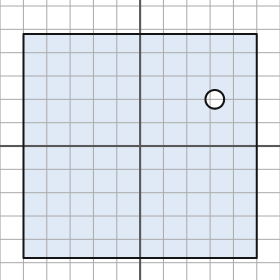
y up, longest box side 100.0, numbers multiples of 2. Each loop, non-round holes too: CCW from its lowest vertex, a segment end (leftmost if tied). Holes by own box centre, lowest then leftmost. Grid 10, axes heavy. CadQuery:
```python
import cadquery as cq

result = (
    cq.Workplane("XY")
    .moveTo(-50.0, -48.0)
    .lineTo(50.0, -48.0)
    .lineTo(50.0, 48.0)
    .lineTo(-50.0, 48.0)
    .close()
    .moveTo(32.0, 20.0)
    .circle(4.0)
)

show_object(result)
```